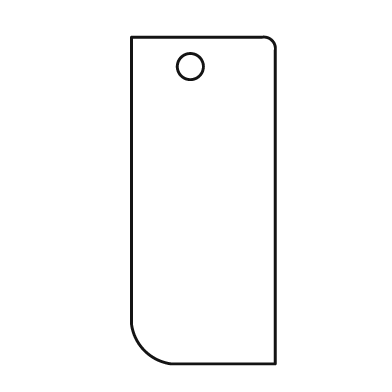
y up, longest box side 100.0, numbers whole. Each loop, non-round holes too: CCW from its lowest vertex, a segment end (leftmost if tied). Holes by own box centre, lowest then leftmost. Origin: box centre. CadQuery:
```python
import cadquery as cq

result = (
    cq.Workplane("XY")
    .moveTo(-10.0, -50.0)
    .lineTo(22.0, -50.0)
    .lineTo(22.0, 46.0)
    .threePointArc((21.0, 49.0), (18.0, 50.0))
    .lineTo(-22.0, 50.0)
    .lineTo(-22.0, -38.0)
    .threePointArc((-18.0, -46.0), (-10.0, -50.0))
    .close()
    .moveTo(-4.0, 41.0)
    .circle(4.0)
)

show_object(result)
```